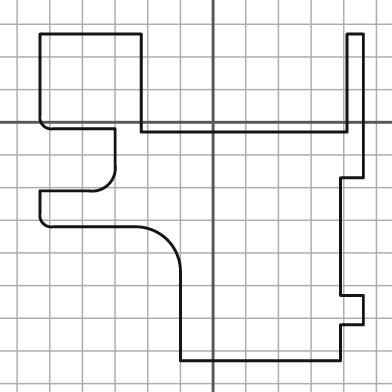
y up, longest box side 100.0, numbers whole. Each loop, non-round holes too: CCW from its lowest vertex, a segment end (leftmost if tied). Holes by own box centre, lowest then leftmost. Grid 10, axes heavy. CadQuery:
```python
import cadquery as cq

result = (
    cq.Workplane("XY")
    .moveTo(-10.0, -73.0)
    .lineTo(39.0, -73.0)
    .lineTo(39.0, -62.0)
    .lineTo(46.0, -62.0)
    .lineTo(46.0, -53.0)
    .lineTo(39.0, -53.0)
    .lineTo(39.0, -17.0)
    .lineTo(46.0, -17.0)
    .lineTo(46.0, 27.0)
    .lineTo(41.0, 27.0)
    .lineTo(41.0, -3.0)
    .lineTo(-22.0, -3.0)
    .lineTo(-22.0, 27.0)
    .lineTo(-53.0, 27.0)
    .lineTo(-53.0, 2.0)
    .threePointArc((-52.0, -1.0), (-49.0, -2.0))
    .lineTo(-30.0, -2.0)
    .lineTo(-30.0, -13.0)
    .threePointArc((-32.0, -19.0), (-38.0, -21.0))
    .lineTo(-53.0, -21.0)
    .lineTo(-53.0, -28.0)
    .threePointArc((-52.0, -31.0), (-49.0, -32.0))
    .lineTo(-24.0, -32.0)
    .threePointArc((-14.0, -36.0), (-10.0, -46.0))
    .close()
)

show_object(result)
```